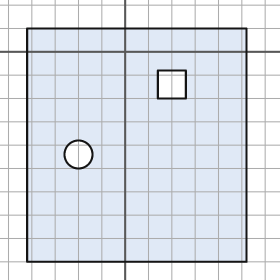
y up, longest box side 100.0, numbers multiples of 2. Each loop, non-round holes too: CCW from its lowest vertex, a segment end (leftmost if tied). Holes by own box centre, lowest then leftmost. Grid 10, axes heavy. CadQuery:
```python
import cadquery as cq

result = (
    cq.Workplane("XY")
    .moveTo(-42.0, -90.0)
    .lineTo(52.0, -90.0)
    .lineTo(52.0, 10.0)
    .lineTo(-42.0, 10.0)
    .close()
    .moveTo(-20.0, -44.0)
    .circle(6.0)
    .moveTo(14.0, -20.0)
    .lineTo(26.0, -20.0)
    .lineTo(26.0, -8.0)
    .lineTo(14.0, -8.0)
    .close()
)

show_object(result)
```